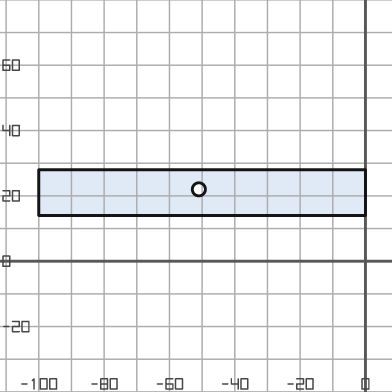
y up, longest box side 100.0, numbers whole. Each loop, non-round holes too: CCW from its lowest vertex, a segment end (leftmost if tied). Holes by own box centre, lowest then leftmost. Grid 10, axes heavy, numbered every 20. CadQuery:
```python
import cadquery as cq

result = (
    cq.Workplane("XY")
    .moveTo(-100.0, 14.0)
    .lineTo(0.0, 14.0)
    .lineTo(0.0, 28.0)
    .lineTo(-100.0, 28.0)
    .close()
    .moveTo(-51.0, 22.0)
    .circle(2.0)
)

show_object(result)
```